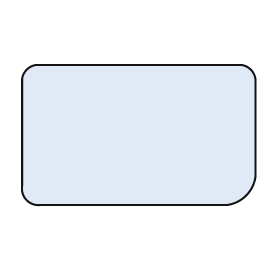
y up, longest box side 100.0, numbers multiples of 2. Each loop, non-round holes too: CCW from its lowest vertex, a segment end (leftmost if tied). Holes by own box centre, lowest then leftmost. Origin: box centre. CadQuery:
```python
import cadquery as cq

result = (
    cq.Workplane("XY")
    .moveTo(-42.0, -30.0)
    .lineTo(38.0, -30.0)
    .threePointArc((46.0, -26.0), (50.0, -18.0))
    .lineTo(50.0, 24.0)
    .threePointArc((48.0, 28.0), (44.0, 30.0))
    .lineTo(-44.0, 30.0)
    .threePointArc((-48.0, 28.0), (-50.0, 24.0))
    .lineTo(-50.0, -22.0)
    .threePointArc((-48.0, -28.0), (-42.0, -30.0))
    .close()
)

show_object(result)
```